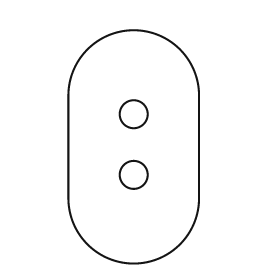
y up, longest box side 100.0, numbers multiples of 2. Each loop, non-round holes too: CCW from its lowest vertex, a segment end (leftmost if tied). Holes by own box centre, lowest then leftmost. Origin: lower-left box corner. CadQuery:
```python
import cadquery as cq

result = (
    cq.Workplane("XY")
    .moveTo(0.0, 28.0)
    .threePointArc((28.0, 0.0), (56.0, 28.0))
    .lineTo(56.0, 72.0)
    .threePointArc((28.0, 100.0), (0.0, 72.0))
    .close()
    .moveTo(28.0, 38.0)
    .circle(6.0)
    .moveTo(28.0, 64.0)
    .circle(6.0)
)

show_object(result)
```